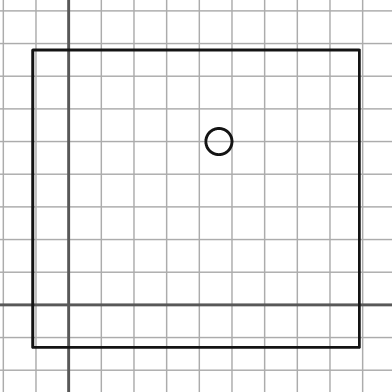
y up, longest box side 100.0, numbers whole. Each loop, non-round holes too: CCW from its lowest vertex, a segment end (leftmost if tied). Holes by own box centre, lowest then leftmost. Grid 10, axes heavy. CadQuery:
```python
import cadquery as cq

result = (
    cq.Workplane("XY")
    .moveTo(-11.0, -13.0)
    .lineTo(89.0, -13.0)
    .lineTo(89.0, 78.0)
    .lineTo(-11.0, 78.0)
    .close()
    .moveTo(46.0, 50.0)
    .circle(4.0)
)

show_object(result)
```